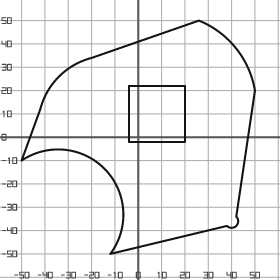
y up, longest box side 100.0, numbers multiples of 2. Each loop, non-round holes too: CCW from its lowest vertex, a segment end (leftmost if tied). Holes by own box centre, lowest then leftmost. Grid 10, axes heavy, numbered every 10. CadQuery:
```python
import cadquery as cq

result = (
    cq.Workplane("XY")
    .moveTo(-12.0, -50.0)
    .lineTo(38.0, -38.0)
    .threePointArc((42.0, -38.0), (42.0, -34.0))
    .lineTo(50.0, 20.0)
    .threePointArc((42.0, 38.0), (26.0, 50.0))
    .lineTo(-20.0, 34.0)
    .threePointArc((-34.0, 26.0), (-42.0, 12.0))
    .lineTo(-50.0, -10.0)
    .threePointArc((-14.0, -14.0), (-12.0, -50.0))
    .close()
    .moveTo(-4.0, -2.0)
    .lineTo(20.0, -2.0)
    .lineTo(20.0, 22.0)
    .lineTo(-4.0, 22.0)
    .close()
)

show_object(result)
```